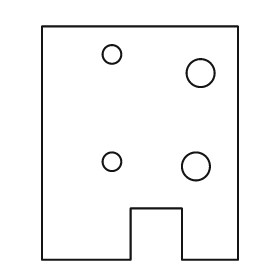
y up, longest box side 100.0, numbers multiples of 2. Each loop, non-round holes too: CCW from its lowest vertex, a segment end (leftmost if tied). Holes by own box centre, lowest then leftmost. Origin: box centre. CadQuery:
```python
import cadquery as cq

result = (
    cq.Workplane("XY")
    .moveTo(-42.0, -50.0)
    .lineTo(-4.0, -50.0)
    .lineTo(-4.0, -28.0)
    .lineTo(18.0, -28.0)
    .lineTo(18.0, -50.0)
    .lineTo(42.0, -50.0)
    .lineTo(42.0, 50.0)
    .lineTo(-42.0, 50.0)
    .close()
    .moveTo(24.0, -10.0)
    .circle(6.0)
    .moveTo(-12.0, -8.0)
    .circle(4.0)
    .moveTo(26.0, 30.0)
    .circle(6.0)
    .moveTo(-12.0, 38.0)
    .circle(4.0)
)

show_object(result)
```